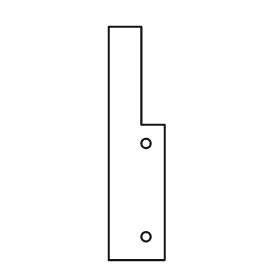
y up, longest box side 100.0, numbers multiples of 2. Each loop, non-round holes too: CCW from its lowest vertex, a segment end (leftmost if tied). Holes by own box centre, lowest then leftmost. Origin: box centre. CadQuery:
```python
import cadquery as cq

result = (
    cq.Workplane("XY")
    .moveTo(-12.0, -50.0)
    .lineTo(12.0, -50.0)
    .lineTo(12.0, 8.0)
    .lineTo(2.0, 8.0)
    .lineTo(2.0, 50.0)
    .lineTo(-12.0, 50.0)
    .close()
    .moveTo(4.0, -40.0)
    .circle(2.0)
    .moveTo(4.0, 0.0)
    .circle(2.0)
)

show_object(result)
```